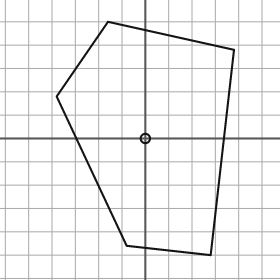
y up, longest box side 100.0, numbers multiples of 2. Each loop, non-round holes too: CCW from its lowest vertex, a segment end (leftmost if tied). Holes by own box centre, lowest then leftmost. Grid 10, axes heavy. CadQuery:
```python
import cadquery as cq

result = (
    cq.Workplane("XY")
    .moveTo(28.0, -50.0)
    .lineTo(38.0, 38.0)
    .lineTo(-16.0, 50.0)
    .lineTo(-38.0, 18.0)
    .lineTo(-8.0, -46.0)
    .close()
    .moveTo(0.0, 0.0)
    .circle(2.0)
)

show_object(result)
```